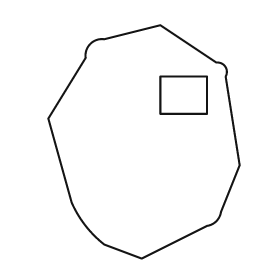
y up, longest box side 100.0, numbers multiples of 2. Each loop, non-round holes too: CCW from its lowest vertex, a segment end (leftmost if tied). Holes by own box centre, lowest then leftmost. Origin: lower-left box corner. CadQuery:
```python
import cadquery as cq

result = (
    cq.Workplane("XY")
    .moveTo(40.0, 0.0)
    .lineTo(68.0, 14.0)
    .threePointArc((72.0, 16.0), (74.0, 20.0))
    .lineTo(82.0, 40.0)
    .lineTo(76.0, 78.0)
    .threePointArc((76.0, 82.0), (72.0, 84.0))
    .lineTo(48.0, 100.0)
    .lineTo(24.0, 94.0)
    .threePointArc((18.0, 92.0), (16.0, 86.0))
    .lineTo(0.0, 60.0)
    .lineTo(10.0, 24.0)
    .threePointArc((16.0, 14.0), (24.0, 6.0))
    .close()
    .moveTo(48.0, 62.0)
    .lineTo(68.0, 62.0)
    .lineTo(68.0, 78.0)
    .lineTo(48.0, 78.0)
    .close()
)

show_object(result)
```